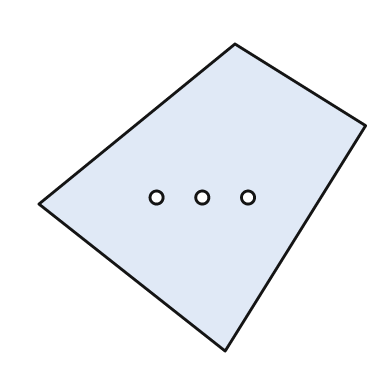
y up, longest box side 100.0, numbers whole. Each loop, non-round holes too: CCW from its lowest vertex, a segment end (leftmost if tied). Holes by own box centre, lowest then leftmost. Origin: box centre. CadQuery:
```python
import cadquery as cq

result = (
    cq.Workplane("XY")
    .moveTo(7.0, -47.0)
    .lineTo(50.0, 22.0)
    .lineTo(10.0, 47.0)
    .lineTo(-50.0, -2.0)
    .close()
    .moveTo(-14.0, 0.0)
    .circle(2.0)
    .moveTo(0.0, 0.0)
    .circle(2.0)
    .moveTo(14.0, 0.0)
    .circle(2.0)
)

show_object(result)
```